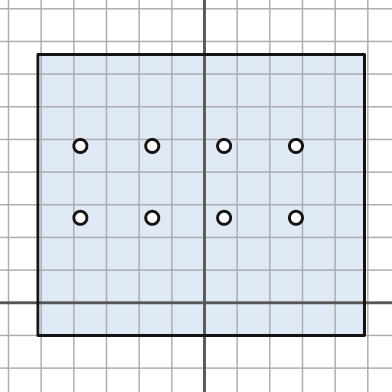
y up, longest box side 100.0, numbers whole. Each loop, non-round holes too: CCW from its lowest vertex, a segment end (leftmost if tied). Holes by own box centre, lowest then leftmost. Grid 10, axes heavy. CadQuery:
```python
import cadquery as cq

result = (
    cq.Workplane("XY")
    .moveTo(-51.0, -10.0)
    .lineTo(49.0, -10.0)
    .lineTo(49.0, 76.0)
    .lineTo(-51.0, 76.0)
    .close()
    .moveTo(-38.0, 26.0)
    .circle(2.0)
    .moveTo(-16.0, 26.0)
    .circle(2.0)
    .moveTo(6.0, 26.0)
    .circle(2.0)
    .moveTo(28.0, 26.0)
    .circle(2.0)
    .moveTo(-38.0, 48.0)
    .circle(2.0)
    .moveTo(-16.0, 48.0)
    .circle(2.0)
    .moveTo(6.0, 48.0)
    .circle(2.0)
    .moveTo(28.0, 48.0)
    .circle(2.0)
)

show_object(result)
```